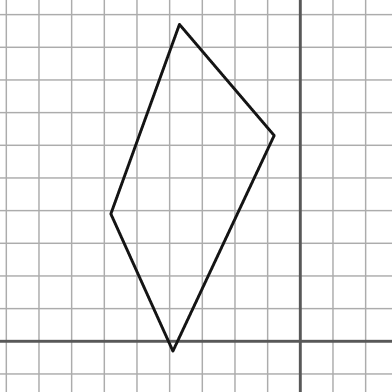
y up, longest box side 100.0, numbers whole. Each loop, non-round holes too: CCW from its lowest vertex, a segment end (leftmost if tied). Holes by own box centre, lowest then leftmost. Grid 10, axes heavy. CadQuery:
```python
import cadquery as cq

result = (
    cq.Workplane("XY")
    .moveTo(-39.0, -3.0)
    .lineTo(-8.0, 63.0)
    .lineTo(-37.0, 97.0)
    .lineTo(-58.0, 39.0)
    .close()
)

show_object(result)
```